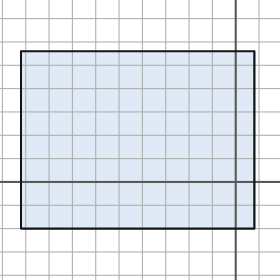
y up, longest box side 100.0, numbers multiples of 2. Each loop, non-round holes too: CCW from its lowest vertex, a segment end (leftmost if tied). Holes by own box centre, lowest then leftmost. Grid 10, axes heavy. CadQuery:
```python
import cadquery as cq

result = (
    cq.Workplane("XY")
    .moveTo(-92.0, -20.0)
    .lineTo(8.0, -20.0)
    .lineTo(8.0, 56.0)
    .lineTo(-92.0, 56.0)
    .close()
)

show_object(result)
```